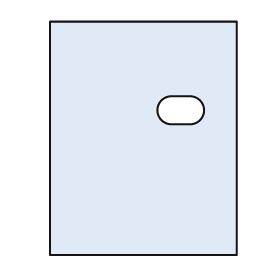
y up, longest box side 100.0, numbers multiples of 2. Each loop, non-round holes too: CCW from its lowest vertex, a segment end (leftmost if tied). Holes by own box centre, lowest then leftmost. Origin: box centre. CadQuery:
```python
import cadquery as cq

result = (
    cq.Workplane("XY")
    .moveTo(-40.0, -50.0)
    .lineTo(40.0, -50.0)
    .lineTo(40.0, 50.0)
    .lineTo(-40.0, 50.0)
    .close()
    .moveTo(12.0, 6.0)
    .lineTo(20.0, 6.0)
    .threePointArc((26.0, 12.0), (20.0, 18.0))
    .lineTo(12.0, 18.0)
    .threePointArc((6.0, 12.0), (12.0, 6.0))
    .close()
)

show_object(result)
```